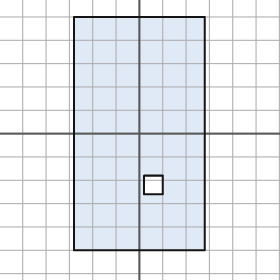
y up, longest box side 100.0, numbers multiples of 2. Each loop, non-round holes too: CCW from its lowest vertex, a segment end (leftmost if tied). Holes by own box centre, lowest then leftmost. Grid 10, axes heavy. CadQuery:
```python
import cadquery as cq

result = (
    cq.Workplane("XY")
    .moveTo(-28.0, -50.0)
    .lineTo(28.0, -50.0)
    .lineTo(28.0, 50.0)
    .lineTo(-28.0, 50.0)
    .close()
    .moveTo(2.0, -26.0)
    .lineTo(10.0, -26.0)
    .lineTo(10.0, -18.0)
    .lineTo(2.0, -18.0)
    .close()
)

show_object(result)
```